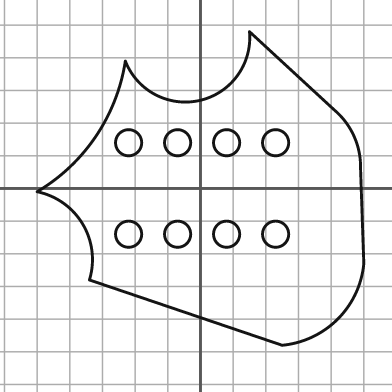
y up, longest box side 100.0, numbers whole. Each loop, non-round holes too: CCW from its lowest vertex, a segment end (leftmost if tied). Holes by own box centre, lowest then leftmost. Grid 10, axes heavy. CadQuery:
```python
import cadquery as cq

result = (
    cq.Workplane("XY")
    .moveTo(25.0, -48.0)
    .threePointArc((42.0, -40.0), (50.0, -23.0))
    .lineTo(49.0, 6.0)
    .threePointArc((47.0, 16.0), (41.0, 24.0))
    .lineTo(15.0, 48.0)
    .threePointArc((0.0, 27.0), (-23.0, 39.0))
    .threePointArc((-32.0, 16.0), (-50.0, -1.0))
    .threePointArc((-36.0, -11.0), (-34.0, -28.0))
    .close()
    .moveTo(-22.0, -14.0)
    .circle(4.0)
    .moveTo(-7.0, -14.0)
    .circle(4.0)
    .moveTo(8.0, -14.0)
    .circle(4.0)
    .moveTo(23.0, -14.0)
    .circle(4.0)
    .moveTo(-22.0, 14.0)
    .circle(4.0)
    .moveTo(-7.0, 14.0)
    .circle(4.0)
    .moveTo(8.0, 14.0)
    .circle(4.0)
    .moveTo(23.0, 14.0)
    .circle(4.0)
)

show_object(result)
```